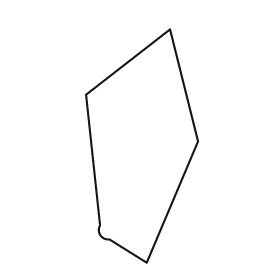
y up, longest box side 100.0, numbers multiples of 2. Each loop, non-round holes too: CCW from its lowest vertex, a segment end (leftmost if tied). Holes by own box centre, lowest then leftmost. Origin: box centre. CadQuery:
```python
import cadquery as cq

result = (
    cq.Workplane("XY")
    .moveTo(2.0, -50.0)
    .lineTo(24.0, 2.0)
    .lineTo(12.0, 50.0)
    .lineTo(-24.0, 22.0)
    .lineTo(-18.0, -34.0)
    .threePointArc((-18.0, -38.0), (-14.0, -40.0))
    .close()
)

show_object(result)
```